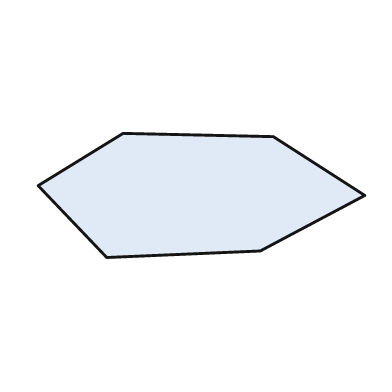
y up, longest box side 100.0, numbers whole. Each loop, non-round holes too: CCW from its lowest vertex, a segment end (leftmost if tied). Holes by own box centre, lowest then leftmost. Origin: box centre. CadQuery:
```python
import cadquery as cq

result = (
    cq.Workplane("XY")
    .moveTo(-29.0, -19.0)
    .lineTo(18.0, -17.0)
    .lineTo(50.0, 0.0)
    .lineTo(22.0, 18.0)
    .lineTo(-24.0, 19.0)
    .lineTo(-50.0, 3.0)
    .close()
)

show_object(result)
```